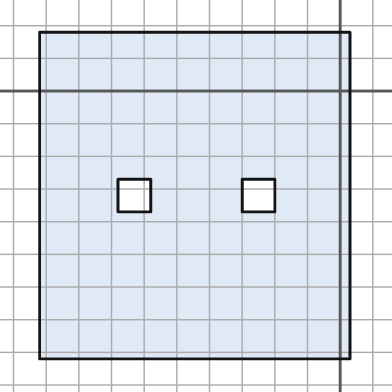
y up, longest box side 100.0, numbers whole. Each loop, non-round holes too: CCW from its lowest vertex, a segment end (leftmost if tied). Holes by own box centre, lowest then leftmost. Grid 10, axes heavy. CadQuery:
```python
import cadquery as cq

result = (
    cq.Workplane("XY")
    .moveTo(-92.0, -82.0)
    .lineTo(3.0, -82.0)
    .lineTo(3.0, 18.0)
    .lineTo(-92.0, 18.0)
    .close()
    .moveTo(-68.0, -37.0)
    .lineTo(-58.0, -37.0)
    .lineTo(-58.0, -27.0)
    .lineTo(-68.0, -27.0)
    .close()
    .moveTo(-30.0, -37.0)
    .lineTo(-20.0, -37.0)
    .lineTo(-20.0, -27.0)
    .lineTo(-30.0, -27.0)
    .close()
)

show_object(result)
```